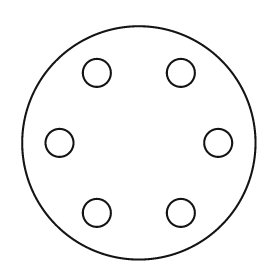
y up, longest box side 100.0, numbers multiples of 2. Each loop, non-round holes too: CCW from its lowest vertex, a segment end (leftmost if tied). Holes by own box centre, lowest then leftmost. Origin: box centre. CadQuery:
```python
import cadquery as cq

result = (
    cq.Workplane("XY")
    .moveTo(0.0, 0.0)
    .circle(50.0)
    .moveTo(-18.0, -30.0)
    .circle(6.0)
    .moveTo(18.0, -30.0)
    .circle(6.0)
    .moveTo(-34.0, 0.0)
    .circle(6.0)
    .moveTo(34.0, 0.0)
    .circle(6.0)
    .moveTo(-18.0, 30.0)
    .circle(6.0)
    .moveTo(18.0, 30.0)
    .circle(6.0)
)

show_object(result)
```